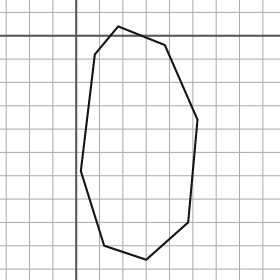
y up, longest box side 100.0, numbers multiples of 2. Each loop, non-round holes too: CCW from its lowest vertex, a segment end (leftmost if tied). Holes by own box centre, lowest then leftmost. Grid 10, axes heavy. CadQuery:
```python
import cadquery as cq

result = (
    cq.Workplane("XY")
    .moveTo(30.0, -96.0)
    .lineTo(48.0, -80.0)
    .lineTo(52.0, -36.0)
    .lineTo(38.0, -4.0)
    .lineTo(18.0, 4.0)
    .lineTo(8.0, -8.0)
    .lineTo(2.0, -58.0)
    .lineTo(12.0, -90.0)
    .close()
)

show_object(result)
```